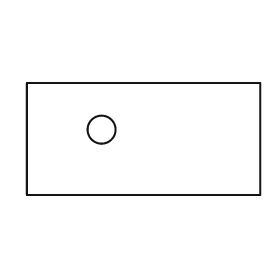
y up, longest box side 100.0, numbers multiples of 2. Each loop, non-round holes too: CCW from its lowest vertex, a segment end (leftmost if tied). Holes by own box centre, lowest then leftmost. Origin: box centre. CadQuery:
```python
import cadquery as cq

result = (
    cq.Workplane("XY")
    .moveTo(-50.0, -24.0)
    .lineTo(50.0, -24.0)
    .lineTo(50.0, 24.0)
    .lineTo(-50.0, 24.0)
    .close()
    .moveTo(-18.0, 4.0)
    .circle(6.0)
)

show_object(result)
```